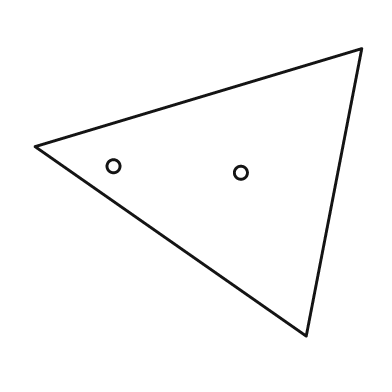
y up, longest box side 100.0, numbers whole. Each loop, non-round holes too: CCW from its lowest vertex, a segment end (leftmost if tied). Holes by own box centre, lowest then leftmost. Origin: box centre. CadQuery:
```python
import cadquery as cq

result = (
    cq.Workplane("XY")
    .moveTo(33.0, -44.0)
    .lineTo(50.0, 44.0)
    .lineTo(-50.0, 14.0)
    .close()
    .moveTo(13.0, 6.0)
    .circle(2.0)
    .moveTo(-26.0, 8.0)
    .circle(2.0)
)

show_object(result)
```